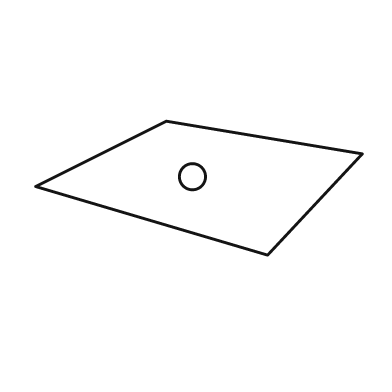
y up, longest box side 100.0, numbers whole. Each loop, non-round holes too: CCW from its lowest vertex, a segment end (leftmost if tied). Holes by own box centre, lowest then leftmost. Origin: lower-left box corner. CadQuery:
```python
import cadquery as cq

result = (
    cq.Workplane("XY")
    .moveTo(71.0, 0.0)
    .lineTo(100.0, 31.0)
    .lineTo(40.0, 41.0)
    .lineTo(0.0, 21.0)
    .close()
    .moveTo(48.0, 24.0)
    .circle(4.0)
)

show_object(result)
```